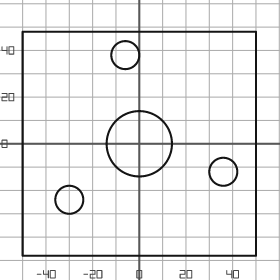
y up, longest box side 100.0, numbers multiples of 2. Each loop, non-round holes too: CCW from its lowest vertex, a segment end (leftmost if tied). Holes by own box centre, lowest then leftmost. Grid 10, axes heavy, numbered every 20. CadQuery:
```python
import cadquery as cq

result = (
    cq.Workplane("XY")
    .moveTo(-50.0, -48.0)
    .lineTo(50.0, -48.0)
    .lineTo(50.0, 48.0)
    .lineTo(-50.0, 48.0)
    .close()
    .moveTo(-30.0, -24.0)
    .circle(6.0)
    .moveTo(36.0, -12.0)
    .circle(6.0)
    .moveTo(0.0, 0.0)
    .circle(14.0)
    .moveTo(-6.0, 38.0)
    .circle(6.0)
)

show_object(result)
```